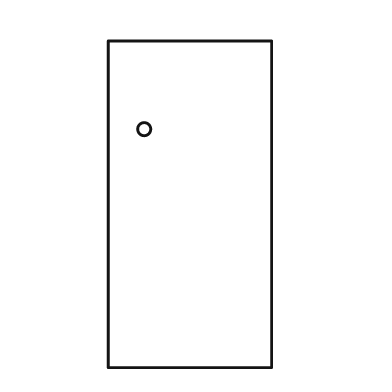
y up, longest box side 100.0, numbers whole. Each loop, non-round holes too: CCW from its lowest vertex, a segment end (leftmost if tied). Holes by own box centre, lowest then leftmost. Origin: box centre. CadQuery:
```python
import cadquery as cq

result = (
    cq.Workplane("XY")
    .moveTo(-25.0, -50.0)
    .lineTo(25.0, -50.0)
    .lineTo(25.0, 50.0)
    .lineTo(-25.0, 50.0)
    .close()
    .moveTo(-14.0, 23.0)
    .circle(2.0)
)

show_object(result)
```